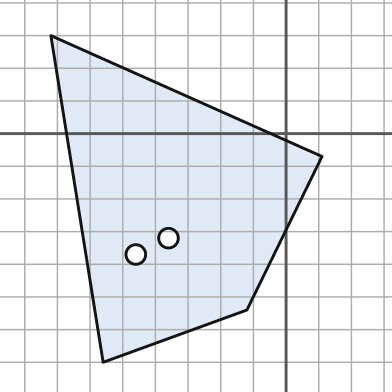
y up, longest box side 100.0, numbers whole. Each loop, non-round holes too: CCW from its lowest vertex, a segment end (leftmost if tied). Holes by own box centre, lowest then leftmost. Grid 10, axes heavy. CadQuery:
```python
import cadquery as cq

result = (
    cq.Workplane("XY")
    .moveTo(-56.0, -70.0)
    .lineTo(-12.0, -54.0)
    .lineTo(11.0, -7.0)
    .lineTo(-72.0, 30.0)
    .close()
    .moveTo(-46.0, -37.0)
    .circle(3.0)
    .moveTo(-36.0, -32.0)
    .circle(3.0)
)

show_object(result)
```